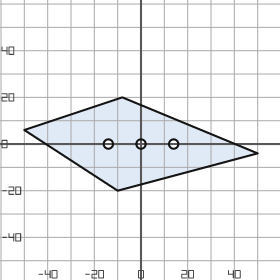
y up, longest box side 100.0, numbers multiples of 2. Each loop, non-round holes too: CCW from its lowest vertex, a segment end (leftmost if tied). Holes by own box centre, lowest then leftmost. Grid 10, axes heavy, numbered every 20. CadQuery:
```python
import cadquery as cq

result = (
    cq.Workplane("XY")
    .moveTo(-10.0, -20.0)
    .lineTo(50.0, -4.0)
    .lineTo(-8.0, 20.0)
    .lineTo(-50.0, 6.0)
    .close()
    .moveTo(-14.0, 0.0)
    .circle(2.0)
    .moveTo(0.0, 0.0)
    .circle(2.0)
    .moveTo(14.0, 0.0)
    .circle(2.0)
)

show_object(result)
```